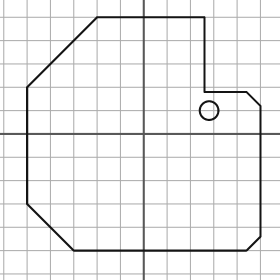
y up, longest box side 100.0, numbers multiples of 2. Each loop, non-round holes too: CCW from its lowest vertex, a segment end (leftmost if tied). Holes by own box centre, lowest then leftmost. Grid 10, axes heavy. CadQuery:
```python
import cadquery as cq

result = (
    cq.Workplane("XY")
    .moveTo(-30.0, -50.0)
    .lineTo(44.0, -50.0)
    .lineTo(50.0, -44.0)
    .lineTo(50.0, 12.0)
    .lineTo(44.0, 18.0)
    .lineTo(26.0, 18.0)
    .lineTo(26.0, 50.0)
    .lineTo(-20.0, 50.0)
    .lineTo(-50.0, 20.0)
    .lineTo(-50.0, -30.0)
    .close()
    .moveTo(28.0, 10.0)
    .circle(4.0)
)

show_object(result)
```